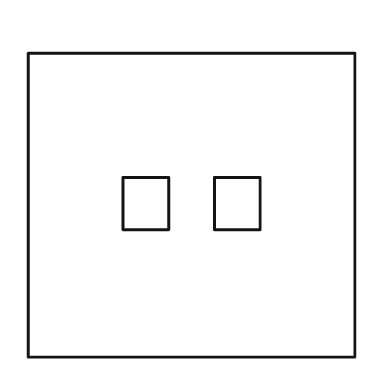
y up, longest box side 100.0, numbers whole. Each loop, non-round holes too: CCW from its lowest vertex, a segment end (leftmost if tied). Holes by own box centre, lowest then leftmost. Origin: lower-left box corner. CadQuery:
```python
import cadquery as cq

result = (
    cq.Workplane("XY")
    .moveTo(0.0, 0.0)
    .lineTo(100.0, 0.0)
    .lineTo(100.0, 93.0)
    .lineTo(0.0, 93.0)
    .close()
    .moveTo(29.0, 39.0)
    .lineTo(43.0, 39.0)
    .lineTo(43.0, 55.0)
    .lineTo(29.0, 55.0)
    .close()
    .moveTo(57.0, 39.0)
    .lineTo(71.0, 39.0)
    .lineTo(71.0, 55.0)
    .lineTo(57.0, 55.0)
    .close()
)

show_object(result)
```